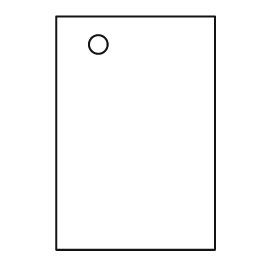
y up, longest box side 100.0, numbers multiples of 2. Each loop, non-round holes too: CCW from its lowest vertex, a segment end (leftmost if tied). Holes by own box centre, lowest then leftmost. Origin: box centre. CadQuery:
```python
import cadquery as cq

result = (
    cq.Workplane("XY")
    .moveTo(-34.0, -50.0)
    .lineTo(34.0, -50.0)
    .lineTo(34.0, 50.0)
    .lineTo(-34.0, 50.0)
    .close()
    .moveTo(-16.0, 38.0)
    .circle(4.0)
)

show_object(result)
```